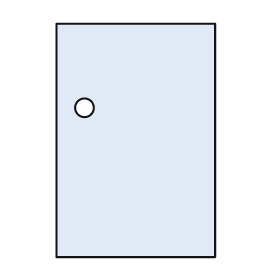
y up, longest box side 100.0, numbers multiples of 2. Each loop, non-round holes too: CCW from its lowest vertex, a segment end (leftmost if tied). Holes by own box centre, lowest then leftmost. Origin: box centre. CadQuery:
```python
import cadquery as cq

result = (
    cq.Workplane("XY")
    .moveTo(-34.0, -50.0)
    .lineTo(34.0, -50.0)
    .lineTo(34.0, 50.0)
    .lineTo(-34.0, 50.0)
    .close()
    .moveTo(-22.0, 14.0)
    .circle(4.0)
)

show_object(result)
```